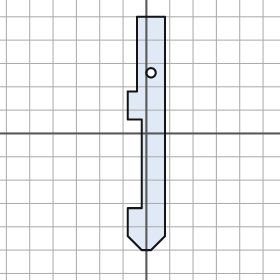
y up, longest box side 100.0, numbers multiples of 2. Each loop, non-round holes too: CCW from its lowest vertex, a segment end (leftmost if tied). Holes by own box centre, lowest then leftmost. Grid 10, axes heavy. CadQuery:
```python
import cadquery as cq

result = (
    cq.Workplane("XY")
    .moveTo(-2.0, -50.0)
    .lineTo(2.0, -50.0)
    .lineTo(8.0, -44.0)
    .lineTo(8.0, 50.0)
    .lineTo(-4.0, 50.0)
    .lineTo(-4.0, 18.0)
    .lineTo(-8.0, 18.0)
    .lineTo(-8.0, 6.0)
    .lineTo(-2.0, 6.0)
    .lineTo(-2.0, -32.0)
    .lineTo(-8.0, -32.0)
    .lineTo(-8.0, -44.0)
    .close()
    .moveTo(2.0, 26.0)
    .circle(2.0)
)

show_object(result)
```